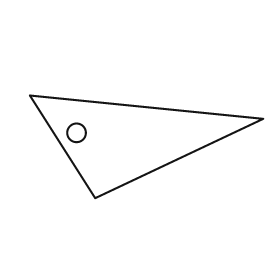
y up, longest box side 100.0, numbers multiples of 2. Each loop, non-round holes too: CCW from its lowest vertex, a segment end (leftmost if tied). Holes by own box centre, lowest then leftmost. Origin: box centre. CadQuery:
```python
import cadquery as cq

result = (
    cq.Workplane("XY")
    .moveTo(-22.0, -22.0)
    .lineTo(50.0, 12.0)
    .lineTo(-50.0, 22.0)
    .close()
    .moveTo(-30.0, 6.0)
    .circle(4.0)
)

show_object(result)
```